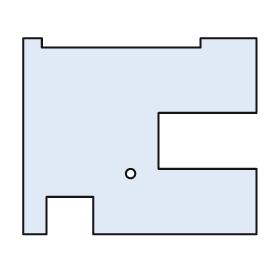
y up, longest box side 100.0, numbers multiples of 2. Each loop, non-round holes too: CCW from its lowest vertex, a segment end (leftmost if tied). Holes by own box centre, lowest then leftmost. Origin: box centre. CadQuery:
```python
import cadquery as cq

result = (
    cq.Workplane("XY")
    .moveTo(-50.0, -42.0)
    .lineTo(-40.0, -42.0)
    .lineTo(-40.0, -26.0)
    .lineTo(-20.0, -26.0)
    .lineTo(-20.0, -42.0)
    .lineTo(50.0, -42.0)
    .lineTo(50.0, -14.0)
    .lineTo(8.0, -14.0)
    .lineTo(8.0, 10.0)
    .lineTo(50.0, 10.0)
    .lineTo(50.0, 42.0)
    .lineTo(26.0, 42.0)
    .lineTo(26.0, 38.0)
    .lineTo(-42.0, 38.0)
    .lineTo(-42.0, 42.0)
    .lineTo(-50.0, 42.0)
    .close()
    .moveTo(-4.0, -16.0)
    .circle(2.0)
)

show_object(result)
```